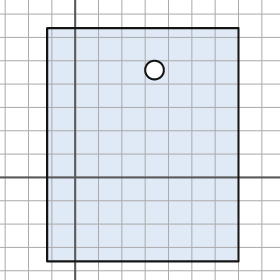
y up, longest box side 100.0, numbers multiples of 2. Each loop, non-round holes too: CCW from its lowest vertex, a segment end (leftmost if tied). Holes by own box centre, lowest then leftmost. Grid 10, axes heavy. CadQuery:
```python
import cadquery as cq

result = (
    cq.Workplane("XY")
    .moveTo(-12.0, -36.0)
    .lineTo(70.0, -36.0)
    .lineTo(70.0, 64.0)
    .lineTo(-12.0, 64.0)
    .close()
    .moveTo(34.0, 46.0)
    .circle(4.0)
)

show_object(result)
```